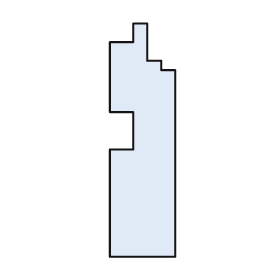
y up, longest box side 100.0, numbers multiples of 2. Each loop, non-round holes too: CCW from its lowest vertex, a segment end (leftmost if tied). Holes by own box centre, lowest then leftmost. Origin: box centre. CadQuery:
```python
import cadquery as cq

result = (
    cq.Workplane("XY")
    .moveTo(-14.0, -50.0)
    .lineTo(14.0, -50.0)
    .lineTo(14.0, 30.0)
    .lineTo(8.0, 30.0)
    .lineTo(8.0, 34.0)
    .lineTo(2.0, 34.0)
    .lineTo(2.0, 50.0)
    .lineTo(-4.0, 50.0)
    .lineTo(-4.0, 42.0)
    .lineTo(-14.0, 42.0)
    .lineTo(-14.0, 12.0)
    .lineTo(-4.0, 12.0)
    .lineTo(-4.0, -4.0)
    .lineTo(-14.0, -4.0)
    .close()
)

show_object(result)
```